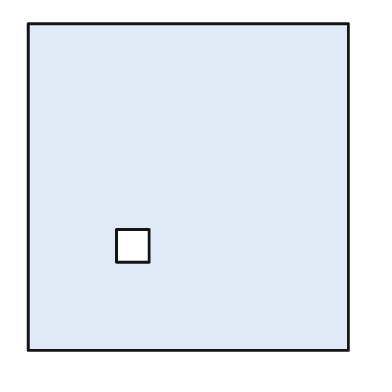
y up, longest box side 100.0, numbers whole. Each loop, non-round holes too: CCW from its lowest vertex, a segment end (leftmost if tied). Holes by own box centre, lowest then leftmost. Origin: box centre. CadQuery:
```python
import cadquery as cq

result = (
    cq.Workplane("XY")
    .moveTo(-49.0, -50.0)
    .lineTo(49.0, -50.0)
    .lineTo(49.0, 50.0)
    .lineTo(-49.0, 50.0)
    .close()
    .moveTo(-22.0, -23.0)
    .lineTo(-12.0, -23.0)
    .lineTo(-12.0, -13.0)
    .lineTo(-22.0, -13.0)
    .close()
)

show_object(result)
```